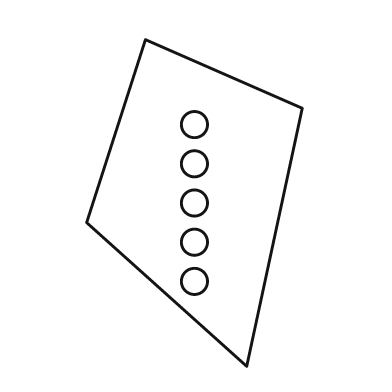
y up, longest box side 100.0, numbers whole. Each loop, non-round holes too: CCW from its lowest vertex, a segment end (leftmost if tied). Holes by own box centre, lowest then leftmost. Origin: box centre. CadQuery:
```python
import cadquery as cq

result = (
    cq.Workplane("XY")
    .moveTo(16.0, -50.0)
    .lineTo(33.0, 29.0)
    .lineTo(-15.0, 50.0)
    .lineTo(-33.0, -6.0)
    .close()
    .moveTo(0.0, -24.0)
    .circle(4.0)
    .moveTo(0.0, -12.0)
    .circle(4.0)
    .moveTo(0.0, 0.0)
    .circle(4.0)
    .moveTo(0.0, 12.0)
    .circle(4.0)
    .moveTo(0.0, 24.0)
    .circle(4.0)
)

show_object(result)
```